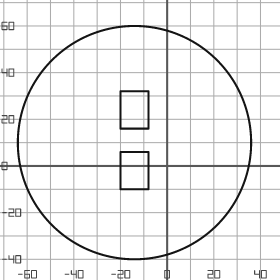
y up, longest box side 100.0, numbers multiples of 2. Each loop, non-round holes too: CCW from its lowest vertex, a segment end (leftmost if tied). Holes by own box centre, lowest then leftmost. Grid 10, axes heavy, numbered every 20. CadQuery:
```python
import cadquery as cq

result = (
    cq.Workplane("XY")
    .moveTo(-14.0, 10.0)
    .circle(50.0)
    .moveTo(-20.0, -10.0)
    .lineTo(-8.0, -10.0)
    .lineTo(-8.0, 6.0)
    .lineTo(-20.0, 6.0)
    .close()
    .moveTo(-20.0, 16.0)
    .lineTo(-8.0, 16.0)
    .lineTo(-8.0, 32.0)
    .lineTo(-20.0, 32.0)
    .close()
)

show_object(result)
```